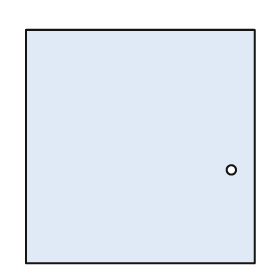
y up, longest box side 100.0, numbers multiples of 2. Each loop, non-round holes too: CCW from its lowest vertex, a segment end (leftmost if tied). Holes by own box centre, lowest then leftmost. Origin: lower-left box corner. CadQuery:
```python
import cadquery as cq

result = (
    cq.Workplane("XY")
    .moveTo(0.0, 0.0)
    .lineTo(98.0, 0.0)
    .lineTo(98.0, 100.0)
    .lineTo(0.0, 100.0)
    .close()
    .moveTo(88.0, 40.0)
    .circle(2.0)
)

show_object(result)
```